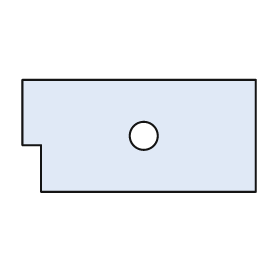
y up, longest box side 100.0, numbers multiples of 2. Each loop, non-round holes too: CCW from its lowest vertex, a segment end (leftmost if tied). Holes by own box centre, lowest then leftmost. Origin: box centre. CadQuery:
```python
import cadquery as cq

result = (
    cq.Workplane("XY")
    .moveTo(-42.0, -24.0)
    .lineTo(50.0, -24.0)
    .lineTo(50.0, 24.0)
    .lineTo(-50.0, 24.0)
    .lineTo(-50.0, -4.0)
    .lineTo(-42.0, -4.0)
    .close()
    .moveTo(2.0, 0.0)
    .circle(6.0)
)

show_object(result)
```